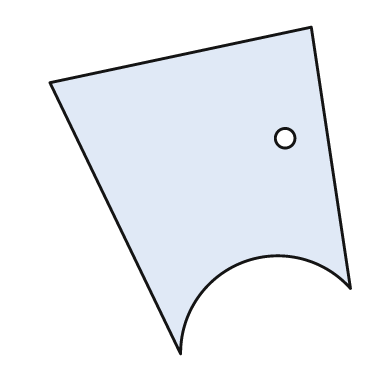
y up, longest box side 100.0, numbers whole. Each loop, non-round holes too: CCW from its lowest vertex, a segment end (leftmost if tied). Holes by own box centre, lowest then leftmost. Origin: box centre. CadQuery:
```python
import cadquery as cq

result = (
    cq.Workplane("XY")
    .moveTo(-6.0, -50.0)
    .threePointArc((13.0, -22.0), (46.0, -30.0))
    .lineTo(34.0, 50.0)
    .lineTo(-46.0, 33.0)
    .close()
    .moveTo(26.0, 16.0)
    .circle(3.0)
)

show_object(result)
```